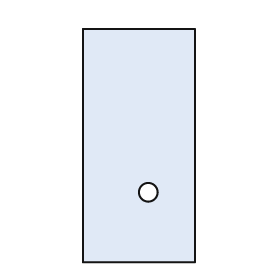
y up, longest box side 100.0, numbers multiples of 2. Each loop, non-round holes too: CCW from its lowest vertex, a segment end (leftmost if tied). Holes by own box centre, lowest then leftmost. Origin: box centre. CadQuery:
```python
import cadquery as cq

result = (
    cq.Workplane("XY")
    .moveTo(-24.0, -50.0)
    .lineTo(24.0, -50.0)
    .lineTo(24.0, 50.0)
    .lineTo(-24.0, 50.0)
    .close()
    .moveTo(4.0, -20.0)
    .circle(4.0)
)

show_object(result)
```